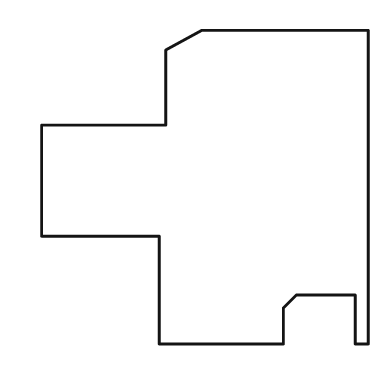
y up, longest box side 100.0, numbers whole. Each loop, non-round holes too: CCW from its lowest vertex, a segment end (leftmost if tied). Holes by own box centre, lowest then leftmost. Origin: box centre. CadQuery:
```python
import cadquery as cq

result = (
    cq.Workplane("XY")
    .moveTo(-14.0, -48.0)
    .lineTo(24.0, -48.0)
    .lineTo(24.0, -37.0)
    .lineTo(28.0, -33.0)
    .lineTo(46.0, -33.0)
    .lineTo(46.0, -48.0)
    .lineTo(50.0, -48.0)
    .lineTo(50.0, 48.0)
    .lineTo(-1.0, 48.0)
    .lineTo(-12.0, 42.0)
    .lineTo(-12.0, 19.0)
    .lineTo(-50.0, 19.0)
    .lineTo(-50.0, -15.0)
    .lineTo(-14.0, -15.0)
    .close()
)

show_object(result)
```